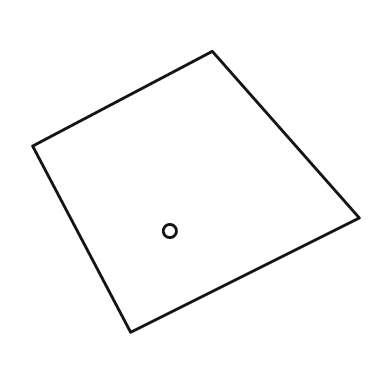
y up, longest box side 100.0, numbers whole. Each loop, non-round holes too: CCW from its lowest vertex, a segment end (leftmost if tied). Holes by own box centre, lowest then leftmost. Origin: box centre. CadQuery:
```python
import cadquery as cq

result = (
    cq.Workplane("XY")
    .moveTo(-20.0, -43.0)
    .lineTo(50.0, -8.0)
    .lineTo(5.0, 43.0)
    .lineTo(-50.0, 14.0)
    .close()
    .moveTo(-8.0, -12.0)
    .circle(2.0)
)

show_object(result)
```